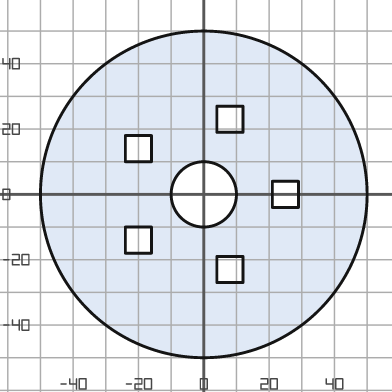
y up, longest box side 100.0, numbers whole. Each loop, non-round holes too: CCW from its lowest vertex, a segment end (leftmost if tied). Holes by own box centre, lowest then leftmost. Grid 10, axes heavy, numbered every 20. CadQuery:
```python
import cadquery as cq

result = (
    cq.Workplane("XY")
    .moveTo(0.0, 0.0)
    .circle(50.0)
    .moveTo(4.0, -27.0)
    .lineTo(12.0, -27.0)
    .lineTo(12.0, -19.0)
    .lineTo(4.0, -19.0)
    .close()
    .moveTo(-24.0, -18.0)
    .lineTo(-16.0, -18.0)
    .lineTo(-16.0, -10.0)
    .lineTo(-24.0, -10.0)
    .close()
    .moveTo(0.0, 0.0)
    .circle(10.0)
    .moveTo(21.0, -4.0)
    .lineTo(29.0, -4.0)
    .lineTo(29.0, 4.0)
    .lineTo(21.0, 4.0)
    .close()
    .moveTo(-24.0, 10.0)
    .lineTo(-16.0, 10.0)
    .lineTo(-16.0, 18.0)
    .lineTo(-24.0, 18.0)
    .close()
    .moveTo(4.0, 19.0)
    .lineTo(12.0, 19.0)
    .lineTo(12.0, 27.0)
    .lineTo(4.0, 27.0)
    .close()
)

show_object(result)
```